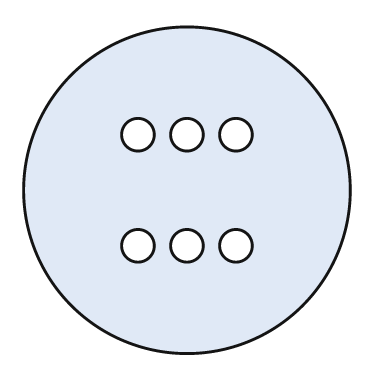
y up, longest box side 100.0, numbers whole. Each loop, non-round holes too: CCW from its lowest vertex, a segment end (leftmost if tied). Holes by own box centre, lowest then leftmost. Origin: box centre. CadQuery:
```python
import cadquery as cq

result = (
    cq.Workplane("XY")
    .moveTo(0.0, 0.0)
    .circle(50.0)
    .moveTo(-15.0, -17.0)
    .circle(5.0)
    .moveTo(0.0, -17.0)
    .circle(5.0)
    .moveTo(15.0, -17.0)
    .circle(5.0)
    .moveTo(-15.0, 17.0)
    .circle(5.0)
    .moveTo(0.0, 17.0)
    .circle(5.0)
    .moveTo(15.0, 17.0)
    .circle(5.0)
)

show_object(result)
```